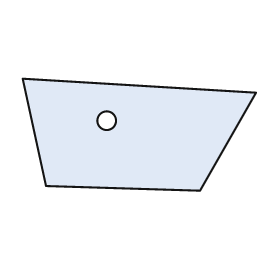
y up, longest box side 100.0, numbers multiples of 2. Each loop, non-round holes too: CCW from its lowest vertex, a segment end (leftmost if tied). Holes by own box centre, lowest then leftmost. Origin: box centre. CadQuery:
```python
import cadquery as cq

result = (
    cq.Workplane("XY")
    .moveTo(26.0, -24.0)
    .lineTo(50.0, 18.0)
    .lineTo(-50.0, 24.0)
    .lineTo(-40.0, -22.0)
    .close()
    .moveTo(-14.0, 6.0)
    .circle(4.0)
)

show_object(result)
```